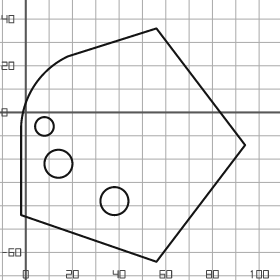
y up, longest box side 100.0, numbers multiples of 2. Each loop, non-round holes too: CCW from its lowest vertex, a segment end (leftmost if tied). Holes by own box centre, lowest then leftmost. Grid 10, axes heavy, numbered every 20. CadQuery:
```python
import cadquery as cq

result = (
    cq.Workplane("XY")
    .moveTo(56.0, -64.0)
    .lineTo(94.0, -14.0)
    .lineTo(56.0, 36.0)
    .lineTo(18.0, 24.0)
    .threePointArc((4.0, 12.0), (-2.0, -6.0))
    .lineTo(-2.0, -44.0)
    .close()
    .moveTo(38.0, -38.0)
    .circle(6.0)
    .moveTo(14.0, -22.0)
    .circle(6.0)
    .moveTo(8.0, -6.0)
    .circle(4.0)
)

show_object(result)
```